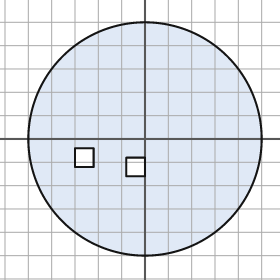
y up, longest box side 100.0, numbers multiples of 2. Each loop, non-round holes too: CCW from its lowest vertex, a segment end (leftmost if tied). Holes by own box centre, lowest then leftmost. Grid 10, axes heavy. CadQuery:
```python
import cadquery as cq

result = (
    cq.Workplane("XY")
    .moveTo(0.0, 0.0)
    .circle(50.0)
    .moveTo(-8.0, -16.0)
    .lineTo(0.0, -16.0)
    .lineTo(0.0, -8.0)
    .lineTo(-8.0, -8.0)
    .close()
    .moveTo(-30.0, -12.0)
    .lineTo(-22.0, -12.0)
    .lineTo(-22.0, -4.0)
    .lineTo(-30.0, -4.0)
    .close()
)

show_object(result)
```